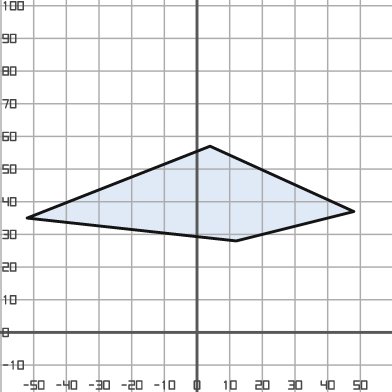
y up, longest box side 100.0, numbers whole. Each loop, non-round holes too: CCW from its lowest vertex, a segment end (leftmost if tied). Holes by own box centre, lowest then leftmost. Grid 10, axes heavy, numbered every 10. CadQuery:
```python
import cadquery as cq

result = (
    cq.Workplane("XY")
    .moveTo(12.0, 28.0)
    .lineTo(48.0, 37.0)
    .lineTo(4.0, 57.0)
    .lineTo(-52.0, 35.0)
    .close()
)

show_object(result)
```